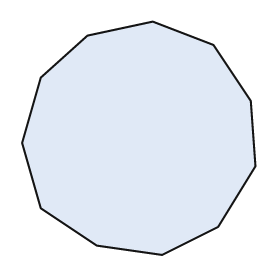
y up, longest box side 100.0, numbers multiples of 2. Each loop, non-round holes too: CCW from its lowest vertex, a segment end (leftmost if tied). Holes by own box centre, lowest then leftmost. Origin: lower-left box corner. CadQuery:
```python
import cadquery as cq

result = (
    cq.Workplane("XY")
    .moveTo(60.0, 0.0)
    .lineTo(84.0, 12.0)
    .lineTo(100.0, 38.0)
    .lineTo(98.0, 66.0)
    .lineTo(82.0, 90.0)
    .lineTo(56.0, 100.0)
    .lineTo(28.0, 94.0)
    .lineTo(8.0, 76.0)
    .lineTo(0.0, 48.0)
    .lineTo(8.0, 20.0)
    .lineTo(32.0, 4.0)
    .close()
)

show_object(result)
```